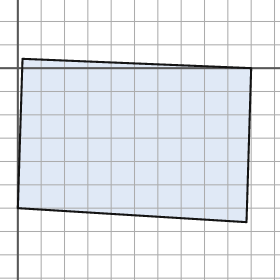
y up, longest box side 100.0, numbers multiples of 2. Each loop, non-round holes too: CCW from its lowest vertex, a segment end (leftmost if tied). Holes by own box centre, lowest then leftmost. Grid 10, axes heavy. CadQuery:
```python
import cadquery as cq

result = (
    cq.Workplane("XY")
    .moveTo(98.0, -66.0)
    .lineTo(100.0, 0.0)
    .lineTo(2.0, 4.0)
    .lineTo(0.0, -60.0)
    .close()
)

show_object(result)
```